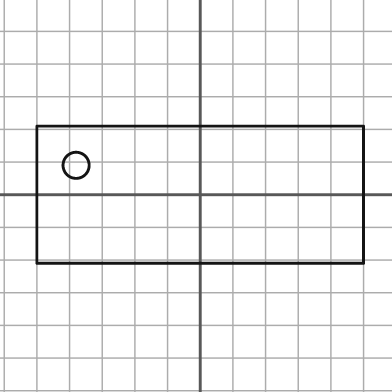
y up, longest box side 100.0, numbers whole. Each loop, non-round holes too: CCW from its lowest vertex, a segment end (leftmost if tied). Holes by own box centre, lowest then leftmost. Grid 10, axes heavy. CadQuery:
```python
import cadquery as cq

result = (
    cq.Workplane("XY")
    .moveTo(-50.0, -21.0)
    .lineTo(50.0, -21.0)
    .lineTo(50.0, 21.0)
    .lineTo(-50.0, 21.0)
    .close()
    .moveTo(-38.0, 9.0)
    .circle(4.0)
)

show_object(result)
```